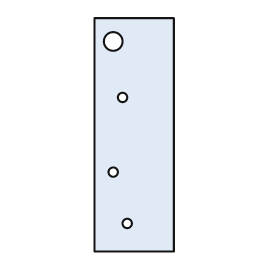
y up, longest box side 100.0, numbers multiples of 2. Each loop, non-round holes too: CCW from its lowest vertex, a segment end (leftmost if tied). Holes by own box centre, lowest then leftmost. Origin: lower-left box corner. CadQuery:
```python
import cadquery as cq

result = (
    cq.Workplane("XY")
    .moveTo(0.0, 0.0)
    .lineTo(34.0, 0.0)
    .lineTo(34.0, 100.0)
    .lineTo(0.0, 100.0)
    .close()
    .moveTo(14.0, 12.0)
    .circle(2.0)
    .moveTo(8.0, 34.0)
    .circle(2.0)
    .moveTo(12.0, 66.0)
    .circle(2.0)
    .moveTo(8.0, 90.0)
    .circle(4.0)
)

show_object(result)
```